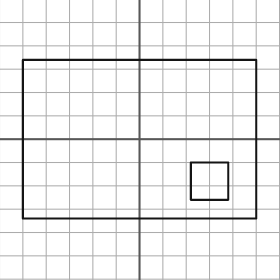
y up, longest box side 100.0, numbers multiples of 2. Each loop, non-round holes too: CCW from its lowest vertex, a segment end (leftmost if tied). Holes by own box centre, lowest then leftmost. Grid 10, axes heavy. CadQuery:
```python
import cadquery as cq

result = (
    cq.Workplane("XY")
    .moveTo(-50.0, -34.0)
    .lineTo(50.0, -34.0)
    .lineTo(50.0, 34.0)
    .lineTo(-50.0, 34.0)
    .close()
    .moveTo(22.0, -26.0)
    .lineTo(38.0, -26.0)
    .lineTo(38.0, -10.0)
    .lineTo(22.0, -10.0)
    .close()
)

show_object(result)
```